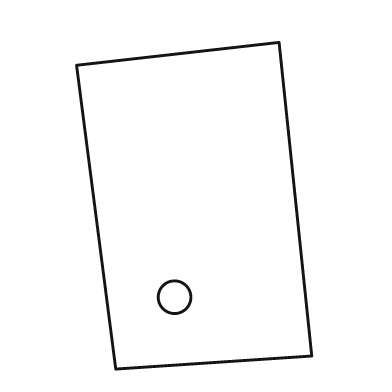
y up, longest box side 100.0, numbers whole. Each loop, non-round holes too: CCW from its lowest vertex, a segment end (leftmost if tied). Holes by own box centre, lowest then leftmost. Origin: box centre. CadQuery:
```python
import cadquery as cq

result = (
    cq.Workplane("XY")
    .moveTo(-24.0, -50.0)
    .lineTo(36.0, -46.0)
    .lineTo(26.0, 50.0)
    .lineTo(-36.0, 43.0)
    .close()
    .moveTo(-6.0, -28.0)
    .circle(5.0)
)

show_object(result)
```